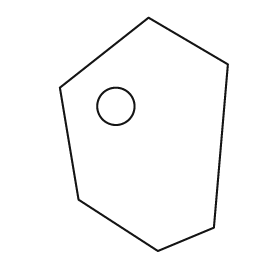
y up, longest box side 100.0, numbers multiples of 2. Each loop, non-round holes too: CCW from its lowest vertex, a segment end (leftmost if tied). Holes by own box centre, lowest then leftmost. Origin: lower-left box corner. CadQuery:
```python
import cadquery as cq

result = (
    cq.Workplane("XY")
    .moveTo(42.0, 0.0)
    .lineTo(66.0, 10.0)
    .lineTo(72.0, 80.0)
    .lineTo(38.0, 100.0)
    .lineTo(0.0, 70.0)
    .lineTo(8.0, 22.0)
    .close()
    .moveTo(24.0, 62.0)
    .circle(8.0)
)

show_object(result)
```